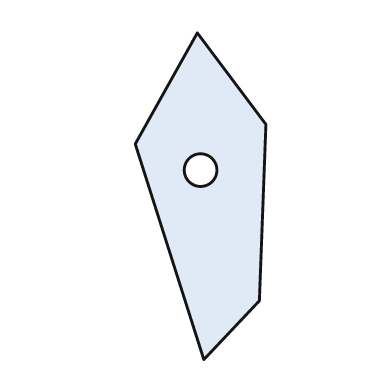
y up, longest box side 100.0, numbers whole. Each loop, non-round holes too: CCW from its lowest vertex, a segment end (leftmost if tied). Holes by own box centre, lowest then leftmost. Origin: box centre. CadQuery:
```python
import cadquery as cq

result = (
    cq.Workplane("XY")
    .moveTo(1.0, -50.0)
    .lineTo(18.0, -32.0)
    .lineTo(20.0, 22.0)
    .lineTo(-1.0, 50.0)
    .lineTo(-20.0, 16.0)
    .close()
    .moveTo(0.0, 8.0)
    .circle(5.0)
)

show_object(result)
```